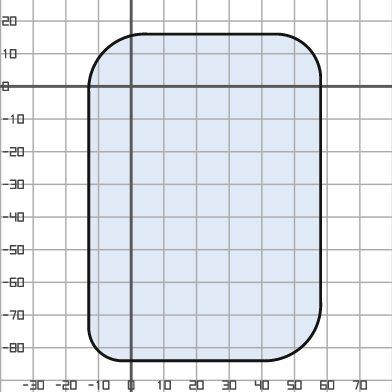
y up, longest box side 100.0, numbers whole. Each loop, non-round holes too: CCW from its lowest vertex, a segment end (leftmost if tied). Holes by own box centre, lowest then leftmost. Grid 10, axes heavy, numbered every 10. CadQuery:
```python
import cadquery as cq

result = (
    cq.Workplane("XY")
    .moveTo(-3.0, -84.0)
    .lineTo(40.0, -84.0)
    .threePointArc((53.0, -79.0), (58.0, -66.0))
    .lineTo(58.0, 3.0)
    .threePointArc((54.0, 12.0), (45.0, 16.0))
    .lineTo(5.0, 16.0)
    .threePointArc((-8.0, 11.0), (-13.0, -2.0))
    .lineTo(-13.0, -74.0)
    .threePointArc((-10.0, -81.0), (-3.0, -84.0))
    .close()
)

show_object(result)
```